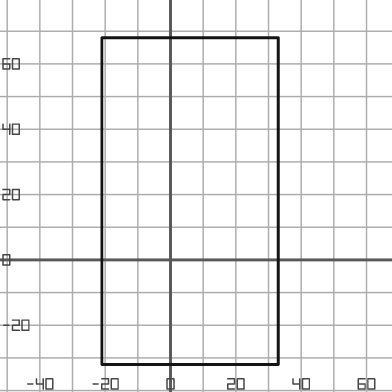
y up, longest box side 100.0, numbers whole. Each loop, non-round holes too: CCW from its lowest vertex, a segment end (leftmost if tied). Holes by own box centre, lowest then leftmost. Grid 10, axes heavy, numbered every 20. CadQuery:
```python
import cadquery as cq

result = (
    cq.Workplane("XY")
    .moveTo(-21.0, -32.0)
    .lineTo(33.0, -32.0)
    .lineTo(33.0, 68.0)
    .lineTo(-21.0, 68.0)
    .close()
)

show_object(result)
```